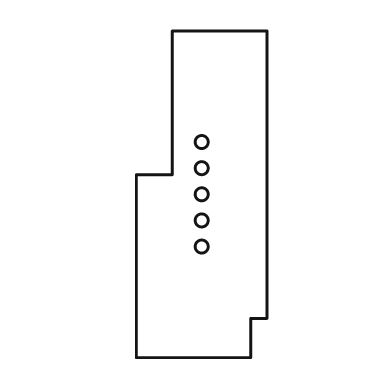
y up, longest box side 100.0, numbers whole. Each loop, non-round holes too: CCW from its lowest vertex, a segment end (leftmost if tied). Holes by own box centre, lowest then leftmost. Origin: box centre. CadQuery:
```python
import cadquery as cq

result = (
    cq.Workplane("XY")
    .moveTo(-20.0, -50.0)
    .lineTo(15.0, -50.0)
    .lineTo(15.0, -38.0)
    .lineTo(20.0, -38.0)
    .lineTo(20.0, 50.0)
    .lineTo(-9.0, 50.0)
    .lineTo(-9.0, 6.0)
    .lineTo(-20.0, 6.0)
    .close()
    .moveTo(0.0, -16.0)
    .circle(2.0)
    .moveTo(0.0, -8.0)
    .circle(2.0)
    .moveTo(0.0, 0.0)
    .circle(2.0)
    .moveTo(0.0, 8.0)
    .circle(2.0)
    .moveTo(0.0, 16.0)
    .circle(2.0)
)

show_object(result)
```